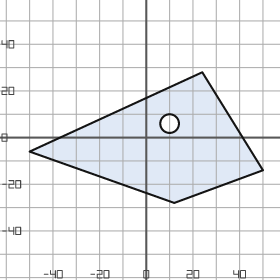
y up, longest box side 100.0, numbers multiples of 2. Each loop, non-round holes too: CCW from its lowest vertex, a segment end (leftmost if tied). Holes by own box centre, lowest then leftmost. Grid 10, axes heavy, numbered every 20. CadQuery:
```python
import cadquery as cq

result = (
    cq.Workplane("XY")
    .moveTo(12.0, -28.0)
    .lineTo(50.0, -14.0)
    .lineTo(24.0, 28.0)
    .lineTo(-50.0, -6.0)
    .close()
    .moveTo(10.0, 6.0)
    .circle(4.0)
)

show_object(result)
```